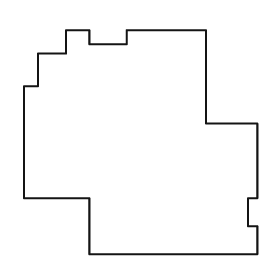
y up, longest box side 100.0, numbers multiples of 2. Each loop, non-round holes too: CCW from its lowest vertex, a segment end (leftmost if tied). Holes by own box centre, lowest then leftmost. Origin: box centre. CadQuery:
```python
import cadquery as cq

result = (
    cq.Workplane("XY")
    .moveTo(-22.0, -48.0)
    .lineTo(50.0, -48.0)
    .lineTo(50.0, -36.0)
    .lineTo(46.0, -36.0)
    .lineTo(46.0, -24.0)
    .lineTo(50.0, -24.0)
    .lineTo(50.0, 8.0)
    .lineTo(28.0, 8.0)
    .lineTo(28.0, 48.0)
    .lineTo(-6.0, 48.0)
    .lineTo(-6.0, 42.0)
    .lineTo(-22.0, 42.0)
    .lineTo(-22.0, 48.0)
    .lineTo(-32.0, 48.0)
    .lineTo(-32.0, 38.0)
    .lineTo(-44.0, 38.0)
    .lineTo(-44.0, 24.0)
    .lineTo(-50.0, 24.0)
    .lineTo(-50.0, -24.0)
    .lineTo(-22.0, -24.0)
    .close()
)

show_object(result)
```